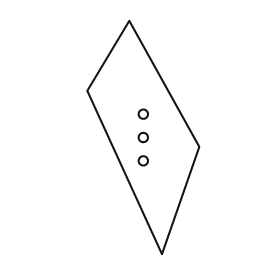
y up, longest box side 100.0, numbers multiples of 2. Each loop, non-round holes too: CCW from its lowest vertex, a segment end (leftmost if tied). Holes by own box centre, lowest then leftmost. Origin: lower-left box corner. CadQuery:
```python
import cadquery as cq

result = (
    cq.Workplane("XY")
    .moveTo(32.0, 0.0)
    .lineTo(48.0, 46.0)
    .lineTo(18.0, 100.0)
    .lineTo(0.0, 70.0)
    .close()
    .moveTo(24.0, 40.0)
    .circle(2.0)
    .moveTo(24.0, 50.0)
    .circle(2.0)
    .moveTo(24.0, 60.0)
    .circle(2.0)
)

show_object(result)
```